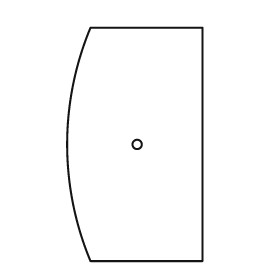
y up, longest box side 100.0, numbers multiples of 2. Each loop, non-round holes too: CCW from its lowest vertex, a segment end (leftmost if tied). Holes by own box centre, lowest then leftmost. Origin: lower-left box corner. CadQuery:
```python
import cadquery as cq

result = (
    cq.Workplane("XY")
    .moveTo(10.0, 0.0)
    .lineTo(58.0, 0.0)
    .lineTo(58.0, 100.0)
    .lineTo(10.0, 100.0)
    .threePointArc((0.0, 50.0), (10.0, 0.0))
    .close()
    .moveTo(30.0, 50.0)
    .circle(2.0)
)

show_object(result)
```